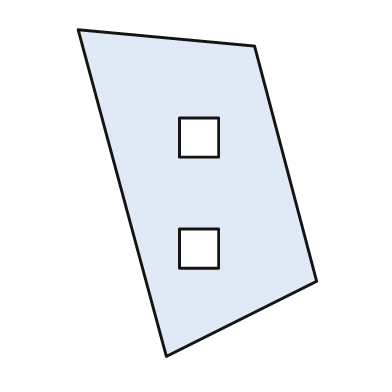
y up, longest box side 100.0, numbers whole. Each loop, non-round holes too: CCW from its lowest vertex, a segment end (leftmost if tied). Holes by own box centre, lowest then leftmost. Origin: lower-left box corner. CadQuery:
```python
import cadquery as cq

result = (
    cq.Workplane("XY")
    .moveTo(27.0, 0.0)
    .lineTo(73.0, 23.0)
    .lineTo(54.0, 95.0)
    .lineTo(0.0, 100.0)
    .close()
    .moveTo(31.0, 27.0)
    .lineTo(43.0, 27.0)
    .lineTo(43.0, 39.0)
    .lineTo(31.0, 39.0)
    .close()
    .moveTo(31.0, 61.0)
    .lineTo(43.0, 61.0)
    .lineTo(43.0, 73.0)
    .lineTo(31.0, 73.0)
    .close()
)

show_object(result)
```